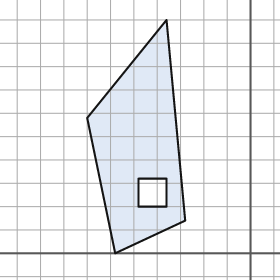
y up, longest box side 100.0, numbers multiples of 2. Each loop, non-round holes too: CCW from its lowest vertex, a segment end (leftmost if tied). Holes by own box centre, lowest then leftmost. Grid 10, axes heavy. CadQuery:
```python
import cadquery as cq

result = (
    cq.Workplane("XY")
    .moveTo(-58.0, 0.0)
    .lineTo(-28.0, 14.0)
    .lineTo(-36.0, 100.0)
    .lineTo(-70.0, 58.0)
    .close()
    .moveTo(-48.0, 20.0)
    .lineTo(-36.0, 20.0)
    .lineTo(-36.0, 32.0)
    .lineTo(-48.0, 32.0)
    .close()
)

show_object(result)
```